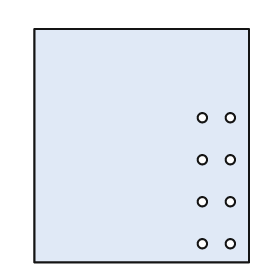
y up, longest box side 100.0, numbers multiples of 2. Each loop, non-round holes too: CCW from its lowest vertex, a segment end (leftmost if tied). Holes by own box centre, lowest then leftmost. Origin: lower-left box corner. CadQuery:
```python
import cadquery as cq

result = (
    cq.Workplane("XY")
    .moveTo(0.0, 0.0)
    .lineTo(92.0, 0.0)
    .lineTo(92.0, 100.0)
    .lineTo(0.0, 100.0)
    .close()
    .moveTo(72.0, 8.0)
    .circle(2.0)
    .moveTo(84.0, 8.0)
    .circle(2.0)
    .moveTo(72.0, 26.0)
    .circle(2.0)
    .moveTo(84.0, 26.0)
    .circle(2.0)
    .moveTo(72.0, 44.0)
    .circle(2.0)
    .moveTo(84.0, 44.0)
    .circle(2.0)
    .moveTo(72.0, 62.0)
    .circle(2.0)
    .moveTo(84.0, 62.0)
    .circle(2.0)
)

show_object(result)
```